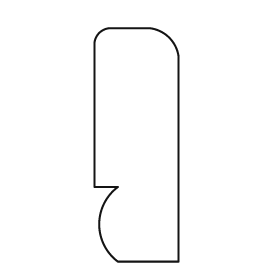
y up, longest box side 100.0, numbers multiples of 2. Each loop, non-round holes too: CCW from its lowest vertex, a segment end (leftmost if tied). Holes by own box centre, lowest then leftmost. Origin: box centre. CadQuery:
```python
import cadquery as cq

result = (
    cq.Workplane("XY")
    .moveTo(-8.0, -50.0)
    .lineTo(18.0, -50.0)
    .lineTo(18.0, 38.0)
    .threePointArc((14.0, 46.0), (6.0, 50.0))
    .lineTo(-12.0, 50.0)
    .threePointArc((-16.0, 48.0), (-18.0, 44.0))
    .lineTo(-18.0, -18.0)
    .lineTo(-8.0, -18.0)
    .threePointArc((-16.0, -34.0), (-8.0, -50.0))
    .close()
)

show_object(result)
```